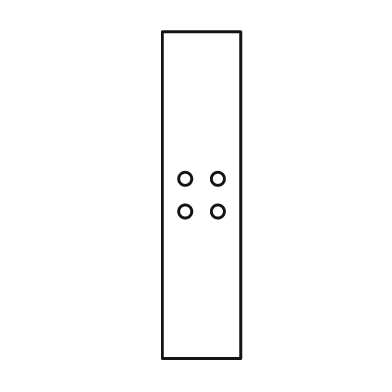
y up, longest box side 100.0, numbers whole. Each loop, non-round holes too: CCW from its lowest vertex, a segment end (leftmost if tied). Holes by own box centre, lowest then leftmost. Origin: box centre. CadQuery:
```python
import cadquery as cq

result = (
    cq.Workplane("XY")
    .moveTo(-12.0, -50.0)
    .lineTo(12.0, -50.0)
    .lineTo(12.0, 50.0)
    .lineTo(-12.0, 50.0)
    .close()
    .moveTo(-5.0, -5.0)
    .circle(2.0)
    .moveTo(5.0, -5.0)
    .circle(2.0)
    .moveTo(-5.0, 5.0)
    .circle(2.0)
    .moveTo(5.0, 5.0)
    .circle(2.0)
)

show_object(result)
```